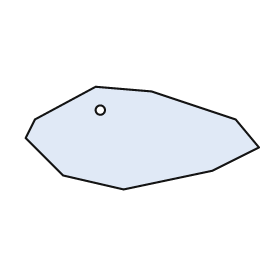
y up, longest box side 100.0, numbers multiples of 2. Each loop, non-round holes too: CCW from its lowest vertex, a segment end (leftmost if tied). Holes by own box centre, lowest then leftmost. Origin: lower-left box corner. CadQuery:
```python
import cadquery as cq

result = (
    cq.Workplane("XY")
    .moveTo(42.0, 0.0)
    .lineTo(80.0, 8.0)
    .lineTo(100.0, 18.0)
    .lineTo(90.0, 30.0)
    .lineTo(54.0, 42.0)
    .lineTo(30.0, 44.0)
    .lineTo(4.0, 30.0)
    .lineTo(0.0, 22.0)
    .lineTo(16.0, 6.0)
    .close()
    .moveTo(32.0, 34.0)
    .circle(2.0)
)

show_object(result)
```